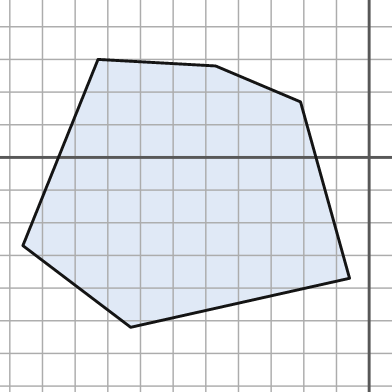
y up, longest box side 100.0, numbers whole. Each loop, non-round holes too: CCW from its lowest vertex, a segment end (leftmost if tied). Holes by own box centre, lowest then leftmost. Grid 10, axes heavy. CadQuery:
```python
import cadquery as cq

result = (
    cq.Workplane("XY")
    .moveTo(-73.0, -52.0)
    .lineTo(-6.0, -37.0)
    .lineTo(-21.0, 17.0)
    .lineTo(-47.0, 28.0)
    .lineTo(-83.0, 30.0)
    .lineTo(-106.0, -27.0)
    .close()
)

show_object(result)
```